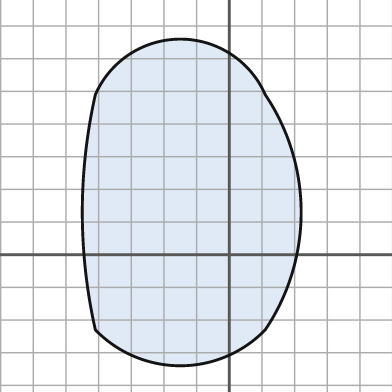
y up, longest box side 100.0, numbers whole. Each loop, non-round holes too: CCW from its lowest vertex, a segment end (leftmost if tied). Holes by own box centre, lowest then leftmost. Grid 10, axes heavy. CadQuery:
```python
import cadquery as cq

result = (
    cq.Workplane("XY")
    .moveTo(-41.0, -23.0)
    .threePointArc((-15.0, -34.0), (11.0, -23.0))
    .threePointArc((22.0, 13.0), (11.0, 49.0))
    .threePointArc((-15.0, 66.0), (-41.0, 49.0))
    .threePointArc((-45.0, 13.0), (-41.0, -23.0))
    .close()
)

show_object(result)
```